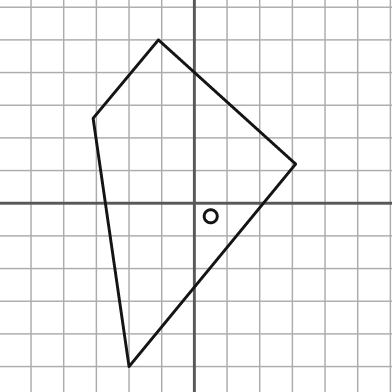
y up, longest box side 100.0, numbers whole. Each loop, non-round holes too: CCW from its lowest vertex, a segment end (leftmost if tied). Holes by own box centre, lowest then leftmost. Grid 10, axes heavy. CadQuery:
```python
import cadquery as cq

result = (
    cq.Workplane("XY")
    .moveTo(-20.0, -50.0)
    .lineTo(31.0, 12.0)
    .lineTo(-11.0, 50.0)
    .lineTo(-31.0, 26.0)
    .close()
    .moveTo(5.0, -4.0)
    .circle(2.0)
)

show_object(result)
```